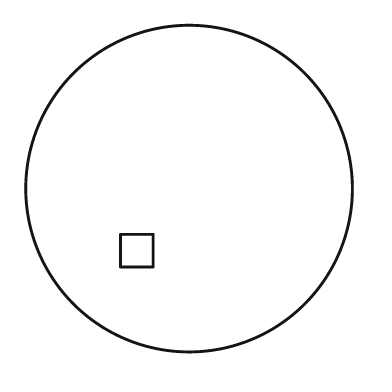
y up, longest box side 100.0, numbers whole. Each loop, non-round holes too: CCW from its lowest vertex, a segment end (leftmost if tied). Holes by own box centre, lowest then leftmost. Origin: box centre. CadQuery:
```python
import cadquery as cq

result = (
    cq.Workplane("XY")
    .moveTo(0.0, 0.0)
    .circle(50.0)
    .moveTo(-21.0, -24.0)
    .lineTo(-11.0, -24.0)
    .lineTo(-11.0, -14.0)
    .lineTo(-21.0, -14.0)
    .close()
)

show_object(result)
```